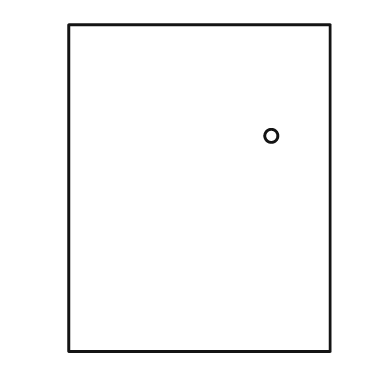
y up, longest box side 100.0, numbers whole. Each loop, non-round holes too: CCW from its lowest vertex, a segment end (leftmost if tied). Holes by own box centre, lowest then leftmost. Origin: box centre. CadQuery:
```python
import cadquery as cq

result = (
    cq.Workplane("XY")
    .moveTo(-40.0, -50.0)
    .lineTo(40.0, -50.0)
    .lineTo(40.0, 50.0)
    .lineTo(-40.0, 50.0)
    .close()
    .moveTo(22.0, 16.0)
    .circle(2.0)
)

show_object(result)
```